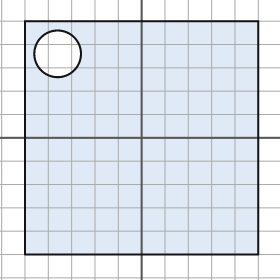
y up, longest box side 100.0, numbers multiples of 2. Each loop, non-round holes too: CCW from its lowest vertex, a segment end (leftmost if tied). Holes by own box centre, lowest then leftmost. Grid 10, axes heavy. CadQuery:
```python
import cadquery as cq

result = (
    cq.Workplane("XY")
    .moveTo(-50.0, -50.0)
    .lineTo(50.0, -50.0)
    .lineTo(50.0, 50.0)
    .lineTo(-50.0, 50.0)
    .close()
    .moveTo(-36.0, 36.0)
    .circle(10.0)
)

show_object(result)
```